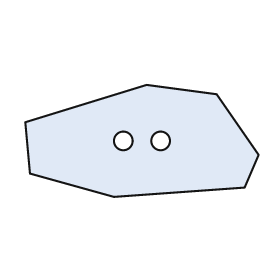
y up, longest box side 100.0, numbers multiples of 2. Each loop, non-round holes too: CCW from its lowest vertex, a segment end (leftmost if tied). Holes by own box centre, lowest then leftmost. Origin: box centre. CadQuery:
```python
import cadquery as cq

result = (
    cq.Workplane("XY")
    .moveTo(-12.0, -24.0)
    .lineTo(44.0, -20.0)
    .lineTo(50.0, -6.0)
    .lineTo(32.0, 20.0)
    .lineTo(2.0, 24.0)
    .lineTo(-50.0, 8.0)
    .lineTo(-48.0, -14.0)
    .close()
    .moveTo(-8.0, 0.0)
    .circle(4.0)
    .moveTo(8.0, 0.0)
    .circle(4.0)
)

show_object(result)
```